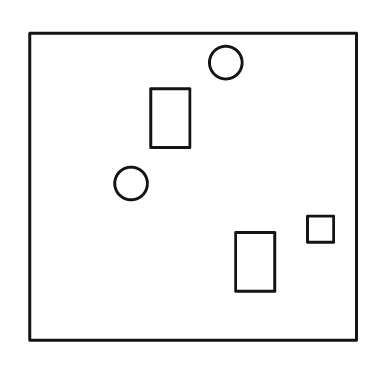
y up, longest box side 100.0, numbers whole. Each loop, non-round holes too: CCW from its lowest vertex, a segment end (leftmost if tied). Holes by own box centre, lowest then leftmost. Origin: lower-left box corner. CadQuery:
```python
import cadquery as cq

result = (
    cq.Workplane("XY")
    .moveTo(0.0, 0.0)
    .lineTo(100.0, 0.0)
    .lineTo(100.0, 94.0)
    .lineTo(0.0, 94.0)
    .close()
    .moveTo(63.0, 15.0)
    .lineTo(75.0, 15.0)
    .lineTo(75.0, 33.0)
    .lineTo(63.0, 33.0)
    .close()
    .moveTo(85.0, 30.0)
    .lineTo(93.0, 30.0)
    .lineTo(93.0, 38.0)
    .lineTo(85.0, 38.0)
    .close()
    .moveTo(31.0, 48.0)
    .circle(5.0)
    .moveTo(37.0, 59.0)
    .lineTo(49.0, 59.0)
    .lineTo(49.0, 77.0)
    .lineTo(37.0, 77.0)
    .close()
    .moveTo(60.0, 85.0)
    .circle(5.0)
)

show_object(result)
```